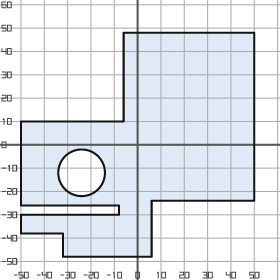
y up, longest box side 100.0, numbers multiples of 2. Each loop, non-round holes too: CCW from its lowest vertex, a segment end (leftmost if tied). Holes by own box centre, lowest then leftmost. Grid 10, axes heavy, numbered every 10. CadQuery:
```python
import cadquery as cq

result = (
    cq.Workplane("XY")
    .moveTo(-32.0, -48.0)
    .lineTo(6.0, -48.0)
    .lineTo(6.0, -24.0)
    .lineTo(50.0, -24.0)
    .lineTo(50.0, 48.0)
    .lineTo(-6.0, 48.0)
    .lineTo(-6.0, 10.0)
    .lineTo(-50.0, 10.0)
    .lineTo(-50.0, -26.0)
    .lineTo(-8.0, -26.0)
    .lineTo(-8.0, -30.0)
    .lineTo(-50.0, -30.0)
    .lineTo(-50.0, -38.0)
    .lineTo(-32.0, -38.0)
    .close()
    .moveTo(-24.0, -12.0)
    .circle(10.0)
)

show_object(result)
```